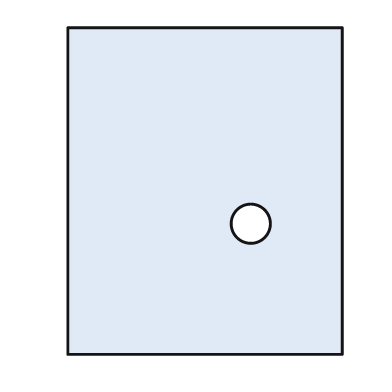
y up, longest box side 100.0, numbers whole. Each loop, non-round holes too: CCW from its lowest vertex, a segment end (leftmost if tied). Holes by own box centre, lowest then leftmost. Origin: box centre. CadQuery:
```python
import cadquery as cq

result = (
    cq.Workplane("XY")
    .moveTo(-42.0, -50.0)
    .lineTo(42.0, -50.0)
    .lineTo(42.0, 50.0)
    .lineTo(-42.0, 50.0)
    .close()
    .moveTo(14.0, -10.0)
    .circle(6.0)
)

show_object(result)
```